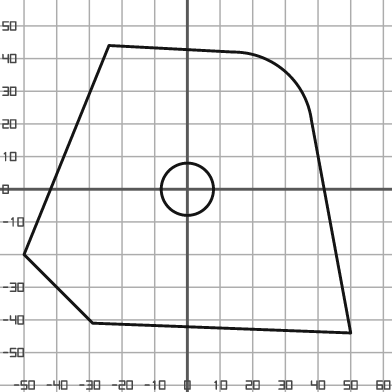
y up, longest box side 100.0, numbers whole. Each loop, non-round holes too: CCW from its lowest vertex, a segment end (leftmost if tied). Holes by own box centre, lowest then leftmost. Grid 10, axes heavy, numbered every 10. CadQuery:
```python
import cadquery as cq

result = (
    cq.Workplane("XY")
    .moveTo(50.0, -44.0)
    .lineTo(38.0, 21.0)
    .threePointArc((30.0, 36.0), (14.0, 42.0))
    .lineTo(-24.0, 44.0)
    .lineTo(-50.0, -20.0)
    .lineTo(-29.0, -41.0)
    .close()
    .moveTo(0.0, 0.0)
    .circle(8.0)
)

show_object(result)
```